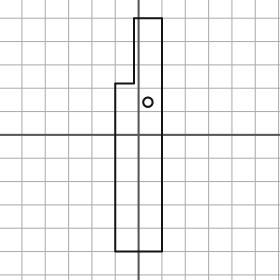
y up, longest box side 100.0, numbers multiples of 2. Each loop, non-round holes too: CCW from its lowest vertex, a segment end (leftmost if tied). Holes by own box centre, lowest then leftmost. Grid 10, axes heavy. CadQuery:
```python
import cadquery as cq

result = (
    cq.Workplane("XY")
    .moveTo(-10.0, -50.0)
    .lineTo(10.0, -50.0)
    .lineTo(10.0, 50.0)
    .lineTo(-2.0, 50.0)
    .lineTo(-2.0, 22.0)
    .lineTo(-10.0, 22.0)
    .close()
    .moveTo(4.0, 14.0)
    .circle(2.0)
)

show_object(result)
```